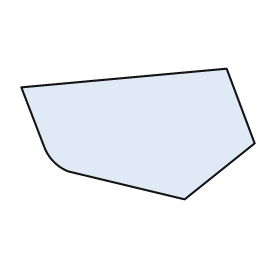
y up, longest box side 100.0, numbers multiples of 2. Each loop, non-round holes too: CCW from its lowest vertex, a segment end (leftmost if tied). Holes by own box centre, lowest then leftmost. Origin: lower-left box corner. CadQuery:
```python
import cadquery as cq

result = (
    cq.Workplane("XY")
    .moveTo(70.0, 0.0)
    .lineTo(100.0, 24.0)
    .lineTo(88.0, 56.0)
    .lineTo(0.0, 48.0)
    .lineTo(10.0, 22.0)
    .threePointArc((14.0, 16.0), (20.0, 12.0))
    .close()
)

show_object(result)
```